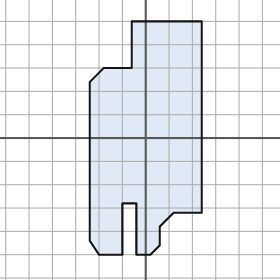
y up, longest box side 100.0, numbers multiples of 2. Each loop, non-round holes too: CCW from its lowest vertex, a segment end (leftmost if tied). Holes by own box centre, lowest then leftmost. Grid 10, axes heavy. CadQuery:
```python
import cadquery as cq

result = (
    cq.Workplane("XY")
    .moveTo(-20.0, -50.0)
    .lineTo(-10.0, -50.0)
    .lineTo(-10.0, -28.0)
    .lineTo(-4.0, -28.0)
    .lineTo(-4.0, -50.0)
    .lineTo(2.0, -50.0)
    .lineTo(6.0, -46.0)
    .lineTo(6.0, -38.0)
    .lineTo(12.0, -32.0)
    .lineTo(24.0, -32.0)
    .lineTo(24.0, 50.0)
    .lineTo(-6.0, 50.0)
    .lineTo(-6.0, 30.0)
    .lineTo(-18.0, 30.0)
    .lineTo(-24.0, 24.0)
    .lineTo(-24.0, -44.0)
    .close()
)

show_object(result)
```